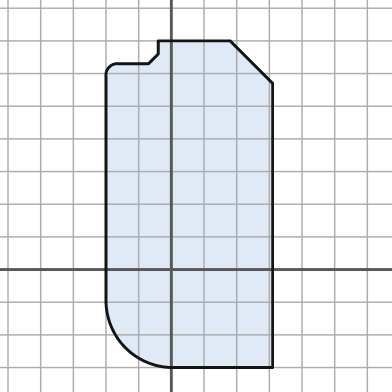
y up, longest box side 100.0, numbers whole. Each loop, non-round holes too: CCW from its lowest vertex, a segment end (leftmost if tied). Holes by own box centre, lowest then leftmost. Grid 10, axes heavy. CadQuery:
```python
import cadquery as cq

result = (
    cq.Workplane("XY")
    .moveTo(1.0, -30.0)
    .lineTo(31.0, -30.0)
    .lineTo(31.0, 57.0)
    .lineTo(18.0, 70.0)
    .lineTo(-4.0, 70.0)
    .lineTo(-4.0, 66.0)
    .lineTo(-7.0, 63.0)
    .lineTo(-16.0, 63.0)
    .threePointArc((-19.0, 62.0), (-20.0, 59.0))
    .lineTo(-20.0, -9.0)
    .threePointArc((-14.0, -24.0), (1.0, -30.0))
    .close()
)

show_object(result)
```